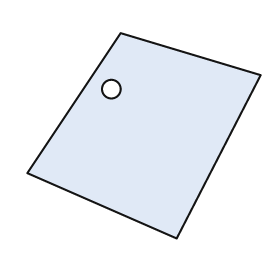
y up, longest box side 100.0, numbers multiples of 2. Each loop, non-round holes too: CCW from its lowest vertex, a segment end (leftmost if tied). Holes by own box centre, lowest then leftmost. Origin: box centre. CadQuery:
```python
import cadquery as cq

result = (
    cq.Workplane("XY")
    .moveTo(14.0, -44.0)
    .lineTo(50.0, 26.0)
    .lineTo(-10.0, 44.0)
    .lineTo(-50.0, -16.0)
    .close()
    .moveTo(-14.0, 20.0)
    .circle(4.0)
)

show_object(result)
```